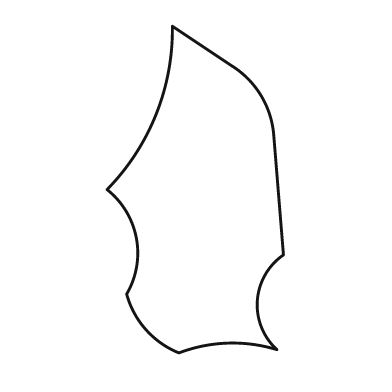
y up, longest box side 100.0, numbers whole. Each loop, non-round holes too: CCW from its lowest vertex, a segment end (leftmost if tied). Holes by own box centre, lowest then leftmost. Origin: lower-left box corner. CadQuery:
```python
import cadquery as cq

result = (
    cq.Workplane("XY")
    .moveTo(22.0, 0.0)
    .threePointArc((37.0, 3.0), (52.0, 1.0))
    .threePointArc((46.0, 16.0), (54.0, 30.0))
    .lineTo(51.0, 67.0)
    .threePointArc((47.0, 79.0), (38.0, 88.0))
    .lineTo(20.0, 100.0)
    .threePointArc((15.0, 73.0), (0.0, 50.0))
    .threePointArc((9.0, 35.0), (6.0, 18.0))
    .threePointArc((12.0, 7.0), (22.0, 0.0))
    .close()
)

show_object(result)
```